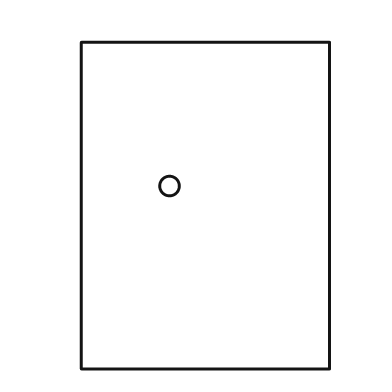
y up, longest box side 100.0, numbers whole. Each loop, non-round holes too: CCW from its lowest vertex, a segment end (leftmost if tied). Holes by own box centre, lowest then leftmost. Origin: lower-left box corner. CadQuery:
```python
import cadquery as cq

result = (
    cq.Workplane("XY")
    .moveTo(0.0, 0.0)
    .lineTo(76.0, 0.0)
    .lineTo(76.0, 100.0)
    .lineTo(0.0, 100.0)
    .close()
    .moveTo(27.0, 56.0)
    .circle(3.0)
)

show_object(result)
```